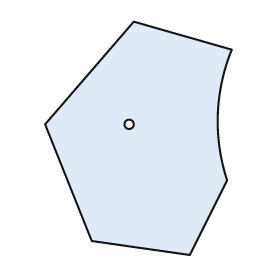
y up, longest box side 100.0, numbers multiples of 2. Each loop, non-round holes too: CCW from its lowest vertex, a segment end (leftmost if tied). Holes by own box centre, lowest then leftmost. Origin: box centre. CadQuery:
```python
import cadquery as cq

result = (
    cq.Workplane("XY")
    .moveTo(22.0, -50.0)
    .lineTo(38.0, -18.0)
    .threePointArc((34.0, 10.0), (40.0, 38.0))
    .lineTo(-2.0, 50.0)
    .lineTo(-40.0, 6.0)
    .lineTo(-20.0, -44.0)
    .close()
    .moveTo(-4.0, 6.0)
    .circle(2.0)
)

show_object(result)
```